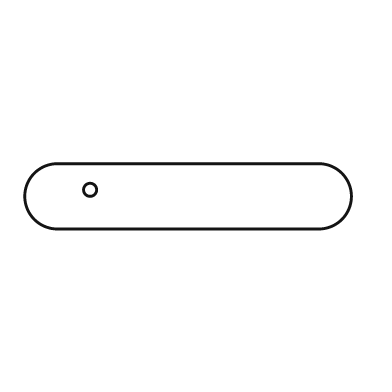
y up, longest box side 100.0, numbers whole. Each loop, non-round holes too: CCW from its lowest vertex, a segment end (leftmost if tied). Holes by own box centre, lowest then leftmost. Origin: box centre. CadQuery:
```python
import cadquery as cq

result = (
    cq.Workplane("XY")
    .moveTo(-40.0, -10.0)
    .lineTo(40.0, -10.0)
    .threePointArc((50.0, 0.0), (40.0, 10.0))
    .lineTo(-40.0, 10.0)
    .threePointArc((-50.0, 0.0), (-40.0, -10.0))
    .close()
    .moveTo(-30.0, 2.0)
    .circle(2.0)
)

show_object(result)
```